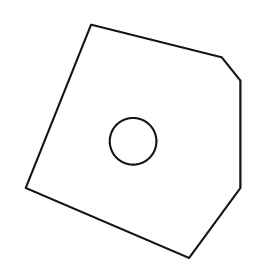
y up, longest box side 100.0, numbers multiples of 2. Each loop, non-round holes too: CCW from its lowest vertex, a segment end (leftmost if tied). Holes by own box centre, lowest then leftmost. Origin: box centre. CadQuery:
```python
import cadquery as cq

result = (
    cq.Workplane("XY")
    .moveTo(24.0, -50.0)
    .lineTo(46.0, -20.0)
    .lineTo(46.0, 26.0)
    .lineTo(38.0, 36.0)
    .lineTo(-18.0, 50.0)
    .lineTo(-46.0, -20.0)
    .close()
    .moveTo(0.0, 0.0)
    .circle(10.0)
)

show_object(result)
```